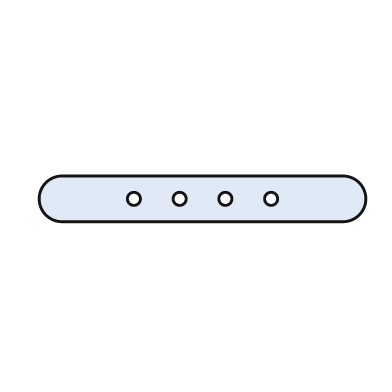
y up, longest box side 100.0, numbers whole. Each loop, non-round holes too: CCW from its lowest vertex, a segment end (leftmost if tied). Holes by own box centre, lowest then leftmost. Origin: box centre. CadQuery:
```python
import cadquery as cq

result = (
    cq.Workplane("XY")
    .moveTo(-43.0, -7.0)
    .lineTo(43.0, -7.0)
    .threePointArc((50.0, 0.0), (43.0, 7.0))
    .lineTo(-43.0, 7.0)
    .threePointArc((-50.0, 0.0), (-43.0, -7.0))
    .close()
    .moveTo(-21.0, 0.0)
    .circle(2.0)
    .moveTo(-7.0, 0.0)
    .circle(2.0)
    .moveTo(7.0, 0.0)
    .circle(2.0)
    .moveTo(21.0, 0.0)
    .circle(2.0)
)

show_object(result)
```